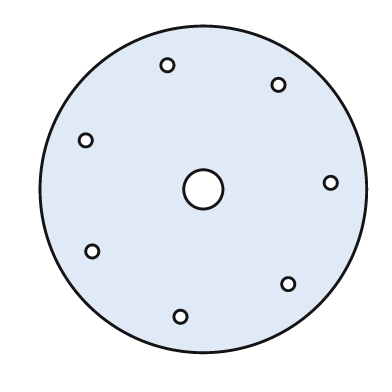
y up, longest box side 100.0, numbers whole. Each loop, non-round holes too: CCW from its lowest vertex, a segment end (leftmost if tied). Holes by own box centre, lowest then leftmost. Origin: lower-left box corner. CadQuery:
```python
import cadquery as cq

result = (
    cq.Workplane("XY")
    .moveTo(50.0, 50.0)
    .circle(50.0)
    .moveTo(43.0, 11.0)
    .circle(2.0)
    .moveTo(76.0, 21.0)
    .circle(2.0)
    .moveTo(16.0, 31.0)
    .circle(2.0)
    .moveTo(50.0, 50.0)
    .circle(6.0)
    .moveTo(89.0, 52.0)
    .circle(2.0)
    .moveTo(14.0, 65.0)
    .circle(2.0)
    .moveTo(73.0, 82.0)
    .circle(2.0)
    .moveTo(39.0, 88.0)
    .circle(2.0)
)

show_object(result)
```